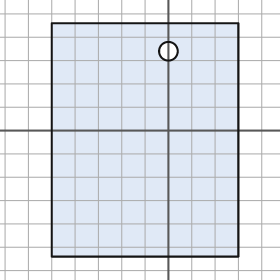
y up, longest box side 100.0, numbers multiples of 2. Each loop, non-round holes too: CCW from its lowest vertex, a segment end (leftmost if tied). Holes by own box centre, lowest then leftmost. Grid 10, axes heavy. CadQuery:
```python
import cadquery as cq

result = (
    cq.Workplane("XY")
    .moveTo(-50.0, -54.0)
    .lineTo(30.0, -54.0)
    .lineTo(30.0, 46.0)
    .lineTo(-50.0, 46.0)
    .close()
    .moveTo(0.0, 34.0)
    .circle(4.0)
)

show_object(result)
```